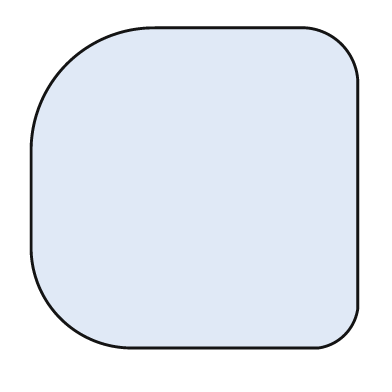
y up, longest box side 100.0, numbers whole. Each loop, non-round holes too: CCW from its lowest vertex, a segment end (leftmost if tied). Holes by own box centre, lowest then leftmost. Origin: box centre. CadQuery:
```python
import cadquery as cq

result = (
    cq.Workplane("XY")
    .moveTo(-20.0, -49.0)
    .lineTo(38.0, -49.0)
    .threePointArc((46.0, -45.0), (50.0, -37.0))
    .lineTo(50.0, 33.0)
    .threePointArc((45.0, 44.0), (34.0, 49.0))
    .lineTo(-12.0, 49.0)
    .threePointArc((-39.0, 38.0), (-50.0, 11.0))
    .lineTo(-50.0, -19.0)
    .threePointArc((-41.0, -40.0), (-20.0, -49.0))
    .close()
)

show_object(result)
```